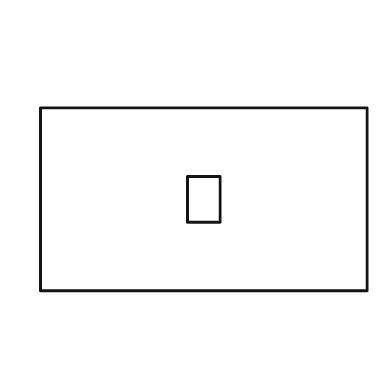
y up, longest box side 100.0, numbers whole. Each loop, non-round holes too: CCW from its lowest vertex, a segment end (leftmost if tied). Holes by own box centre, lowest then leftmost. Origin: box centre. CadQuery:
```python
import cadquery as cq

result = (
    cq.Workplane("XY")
    .moveTo(-50.0, -28.0)
    .lineTo(50.0, -28.0)
    .lineTo(50.0, 28.0)
    .lineTo(-50.0, 28.0)
    .close()
    .moveTo(-5.0, -7.0)
    .lineTo(5.0, -7.0)
    .lineTo(5.0, 7.0)
    .lineTo(-5.0, 7.0)
    .close()
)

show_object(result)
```